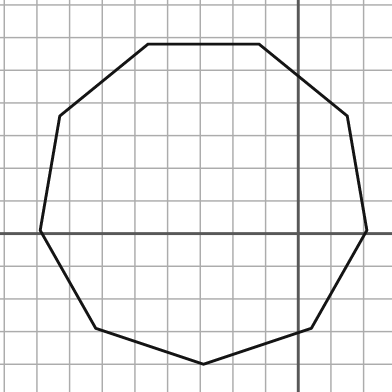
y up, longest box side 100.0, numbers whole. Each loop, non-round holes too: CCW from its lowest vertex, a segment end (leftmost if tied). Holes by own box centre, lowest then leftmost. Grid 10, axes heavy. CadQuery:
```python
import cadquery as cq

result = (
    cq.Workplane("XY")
    .moveTo(-29.0, -40.0)
    .lineTo(4.0, -29.0)
    .lineTo(21.0, 1.0)
    .lineTo(15.0, 36.0)
    .lineTo(-12.0, 58.0)
    .lineTo(-46.0, 58.0)
    .lineTo(-73.0, 36.0)
    .lineTo(-79.0, 1.0)
    .lineTo(-62.0, -29.0)
    .close()
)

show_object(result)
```